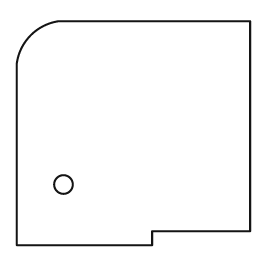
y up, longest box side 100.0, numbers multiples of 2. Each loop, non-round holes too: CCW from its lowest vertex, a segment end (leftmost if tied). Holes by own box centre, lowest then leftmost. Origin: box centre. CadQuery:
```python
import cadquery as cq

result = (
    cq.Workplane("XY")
    .moveTo(-50.0, -48.0)
    .lineTo(8.0, -48.0)
    .lineTo(8.0, -42.0)
    .lineTo(50.0, -42.0)
    .lineTo(50.0, 48.0)
    .lineTo(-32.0, 48.0)
    .threePointArc((-44.0, 42.0), (-50.0, 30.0))
    .close()
    .moveTo(-30.0, -22.0)
    .circle(4.0)
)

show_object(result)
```